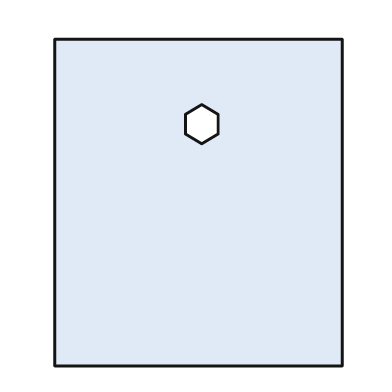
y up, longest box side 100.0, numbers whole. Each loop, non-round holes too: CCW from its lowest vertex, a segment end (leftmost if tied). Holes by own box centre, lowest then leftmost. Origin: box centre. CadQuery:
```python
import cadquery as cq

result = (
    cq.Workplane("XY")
    .moveTo(-44.0, -50.0)
    .lineTo(44.0, -50.0)
    .lineTo(44.0, 50.0)
    .lineTo(-44.0, 50.0)
    .close()
    .moveTo(1.0, 18.0)
    .lineTo(6.0, 21.0)
    .lineTo(6.0, 27.0)
    .lineTo(1.0, 30.0)
    .lineTo(-4.0, 27.0)
    .lineTo(-4.0, 21.0)
    .close()
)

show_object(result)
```